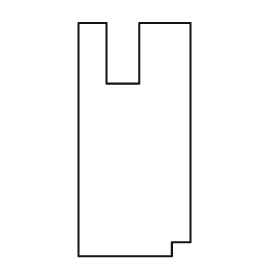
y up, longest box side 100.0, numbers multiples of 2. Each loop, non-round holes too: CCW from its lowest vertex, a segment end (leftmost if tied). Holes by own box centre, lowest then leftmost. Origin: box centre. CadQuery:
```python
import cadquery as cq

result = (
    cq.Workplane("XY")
    .moveTo(-24.0, -50.0)
    .lineTo(16.0, -50.0)
    .lineTo(16.0, -44.0)
    .lineTo(24.0, -44.0)
    .lineTo(24.0, 50.0)
    .lineTo(2.0, 50.0)
    .lineTo(2.0, 24.0)
    .lineTo(-12.0, 24.0)
    .lineTo(-12.0, 50.0)
    .lineTo(-24.0, 50.0)
    .close()
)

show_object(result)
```